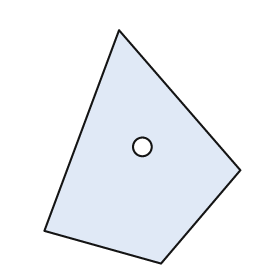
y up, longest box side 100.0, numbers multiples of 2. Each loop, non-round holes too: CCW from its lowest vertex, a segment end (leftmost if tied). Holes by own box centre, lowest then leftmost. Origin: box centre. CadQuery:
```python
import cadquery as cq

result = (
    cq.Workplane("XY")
    .moveTo(8.0, -50.0)
    .lineTo(42.0, -10.0)
    .lineTo(-10.0, 50.0)
    .lineTo(-42.0, -36.0)
    .close()
    .moveTo(0.0, 0.0)
    .circle(4.0)
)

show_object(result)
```